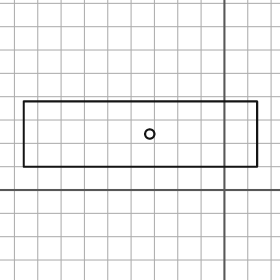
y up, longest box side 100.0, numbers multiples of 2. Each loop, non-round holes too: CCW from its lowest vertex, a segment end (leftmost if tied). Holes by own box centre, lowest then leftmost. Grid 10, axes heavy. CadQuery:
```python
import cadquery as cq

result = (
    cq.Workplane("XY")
    .moveTo(-86.0, 10.0)
    .lineTo(14.0, 10.0)
    .lineTo(14.0, 38.0)
    .lineTo(-86.0, 38.0)
    .close()
    .moveTo(-32.0, 24.0)
    .circle(2.0)
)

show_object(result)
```